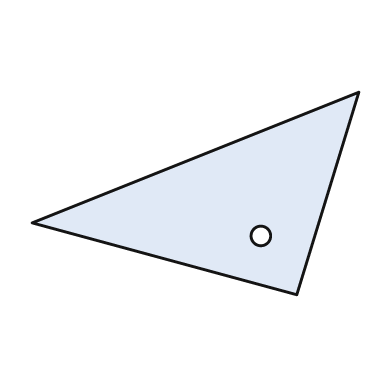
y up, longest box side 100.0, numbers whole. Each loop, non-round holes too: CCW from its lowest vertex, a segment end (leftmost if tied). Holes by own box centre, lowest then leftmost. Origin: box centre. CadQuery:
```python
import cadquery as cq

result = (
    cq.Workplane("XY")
    .moveTo(31.0, -31.0)
    .lineTo(50.0, 31.0)
    .lineTo(-50.0, -9.0)
    .close()
    .moveTo(20.0, -13.0)
    .circle(3.0)
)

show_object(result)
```